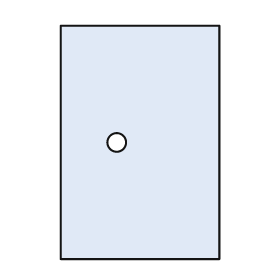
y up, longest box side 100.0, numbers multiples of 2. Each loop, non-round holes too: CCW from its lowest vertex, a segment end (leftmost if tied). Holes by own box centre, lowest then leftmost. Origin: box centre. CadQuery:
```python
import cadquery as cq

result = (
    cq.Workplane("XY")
    .moveTo(-34.0, -50.0)
    .lineTo(34.0, -50.0)
    .lineTo(34.0, 50.0)
    .lineTo(-34.0, 50.0)
    .close()
    .moveTo(-10.0, 0.0)
    .circle(4.0)
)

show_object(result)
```